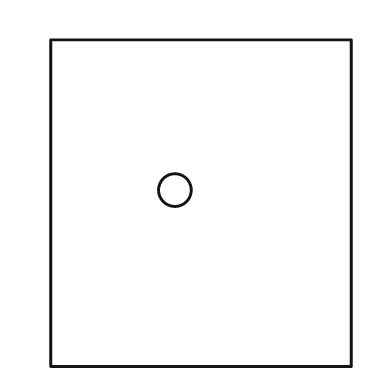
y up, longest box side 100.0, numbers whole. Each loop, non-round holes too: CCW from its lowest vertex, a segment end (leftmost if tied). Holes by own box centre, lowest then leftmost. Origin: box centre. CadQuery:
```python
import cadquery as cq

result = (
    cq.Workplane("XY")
    .moveTo(-46.0, -50.0)
    .lineTo(46.0, -50.0)
    .lineTo(46.0, 50.0)
    .lineTo(-46.0, 50.0)
    .close()
    .moveTo(-8.0, 4.0)
    .circle(5.0)
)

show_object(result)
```